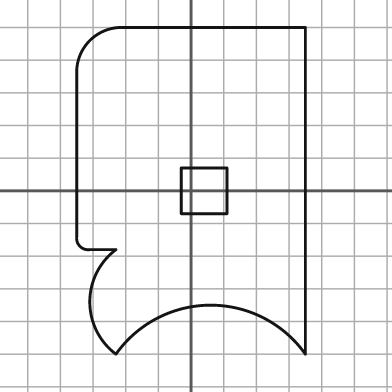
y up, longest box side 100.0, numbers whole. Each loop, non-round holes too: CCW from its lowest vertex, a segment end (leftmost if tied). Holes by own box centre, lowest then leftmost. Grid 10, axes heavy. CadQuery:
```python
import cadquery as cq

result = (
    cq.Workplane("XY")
    .moveTo(-23.0, -50.0)
    .threePointArc((6.0, -35.0), (35.0, -50.0))
    .lineTo(35.0, 50.0)
    .lineTo(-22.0, 50.0)
    .threePointArc((-31.0, 46.0), (-35.0, 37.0))
    .lineTo(-35.0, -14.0)
    .threePointArc((-34.0, -17.0), (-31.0, -18.0))
    .lineTo(-23.0, -18.0)
    .threePointArc((-31.0, -34.0), (-23.0, -50.0))
    .close()
    .moveTo(-3.0, -7.0)
    .lineTo(11.0, -7.0)
    .lineTo(11.0, 7.0)
    .lineTo(-3.0, 7.0)
    .close()
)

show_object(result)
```